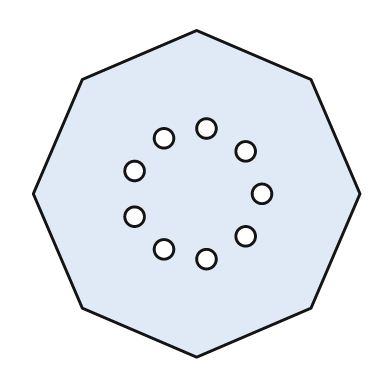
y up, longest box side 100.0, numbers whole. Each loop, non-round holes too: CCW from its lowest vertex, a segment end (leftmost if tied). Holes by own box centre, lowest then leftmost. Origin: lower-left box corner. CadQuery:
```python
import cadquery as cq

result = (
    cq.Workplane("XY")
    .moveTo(50.0, 0.0)
    .lineTo(85.0, 15.0)
    .lineTo(100.0, 50.0)
    .lineTo(85.0, 85.0)
    .lineTo(50.0, 100.0)
    .lineTo(15.0, 85.0)
    .lineTo(0.0, 50.0)
    .lineTo(15.0, 15.0)
    .close()
    .moveTo(53.0, 30.0)
    .circle(3.0)
    .moveTo(40.0, 33.0)
    .circle(3.0)
    .moveTo(65.0, 37.0)
    .circle(3.0)
    .moveTo(31.0, 43.0)
    .circle(3.0)
    .moveTo(70.0, 50.0)
    .circle(3.0)
    .moveTo(31.0, 57.0)
    .circle(3.0)
    .moveTo(65.0, 63.0)
    .circle(3.0)
    .moveTo(40.0, 67.0)
    .circle(3.0)
    .moveTo(53.0, 70.0)
    .circle(3.0)
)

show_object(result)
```